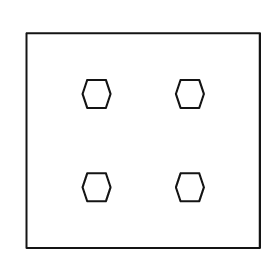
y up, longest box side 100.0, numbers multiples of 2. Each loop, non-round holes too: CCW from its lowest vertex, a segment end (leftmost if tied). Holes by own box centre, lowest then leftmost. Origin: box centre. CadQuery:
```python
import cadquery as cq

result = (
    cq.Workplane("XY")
    .moveTo(-50.0, -46.0)
    .lineTo(50.0, -46.0)
    .lineTo(50.0, 46.0)
    .lineTo(-50.0, 46.0)
    .close()
    .moveTo(-24.0, -26.0)
    .lineTo(-16.0, -26.0)
    .lineTo(-14.0, -20.0)
    .lineTo(-16.0, -14.0)
    .lineTo(-24.0, -14.0)
    .lineTo(-26.0, -20.0)
    .close()
    .moveTo(16.0, -26.0)
    .lineTo(24.0, -26.0)
    .lineTo(26.0, -20.0)
    .lineTo(24.0, -14.0)
    .lineTo(16.0, -14.0)
    .lineTo(14.0, -20.0)
    .close()
    .moveTo(-24.0, 14.0)
    .lineTo(-16.0, 14.0)
    .lineTo(-14.0, 20.0)
    .lineTo(-16.0, 26.0)
    .lineTo(-24.0, 26.0)
    .lineTo(-26.0, 20.0)
    .close()
    .moveTo(16.0, 14.0)
    .lineTo(24.0, 14.0)
    .lineTo(26.0, 20.0)
    .lineTo(24.0, 26.0)
    .lineTo(16.0, 26.0)
    .lineTo(14.0, 20.0)
    .close()
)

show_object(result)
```